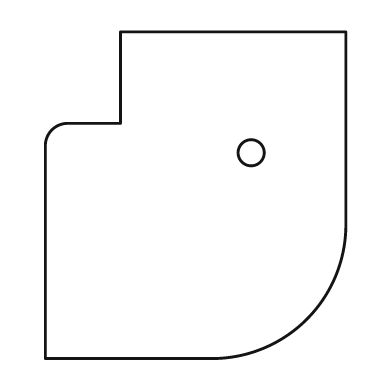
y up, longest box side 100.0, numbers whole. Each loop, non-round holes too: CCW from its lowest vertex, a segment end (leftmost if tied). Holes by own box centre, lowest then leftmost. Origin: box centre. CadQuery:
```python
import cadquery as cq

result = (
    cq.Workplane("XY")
    .moveTo(-46.0, -50.0)
    .lineTo(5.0, -50.0)
    .threePointArc((34.0, -38.0), (46.0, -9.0))
    .lineTo(46.0, 50.0)
    .lineTo(-23.0, 50.0)
    .lineTo(-23.0, 22.0)
    .lineTo(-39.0, 22.0)
    .threePointArc((-44.0, 20.0), (-46.0, 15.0))
    .close()
    .moveTo(17.0, 13.0)
    .circle(4.0)
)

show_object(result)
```